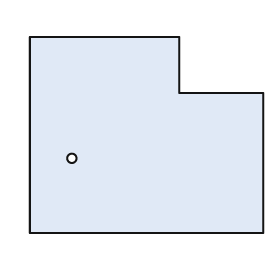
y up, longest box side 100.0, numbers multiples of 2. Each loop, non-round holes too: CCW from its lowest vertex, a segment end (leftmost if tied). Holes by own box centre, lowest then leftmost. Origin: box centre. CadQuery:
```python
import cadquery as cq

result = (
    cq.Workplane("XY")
    .moveTo(-50.0, -42.0)
    .lineTo(50.0, -42.0)
    .lineTo(50.0, 18.0)
    .lineTo(14.0, 18.0)
    .lineTo(14.0, 42.0)
    .lineTo(-50.0, 42.0)
    .close()
    .moveTo(-32.0, -10.0)
    .circle(2.0)
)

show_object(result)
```